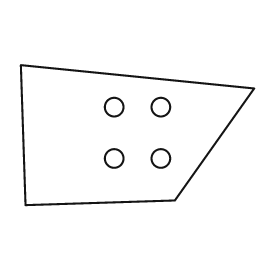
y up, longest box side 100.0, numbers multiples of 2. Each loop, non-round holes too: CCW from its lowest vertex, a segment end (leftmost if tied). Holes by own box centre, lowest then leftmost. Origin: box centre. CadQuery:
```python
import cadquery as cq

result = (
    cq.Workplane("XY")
    .moveTo(-48.0, -30.0)
    .lineTo(16.0, -28.0)
    .lineTo(50.0, 20.0)
    .lineTo(-50.0, 30.0)
    .close()
    .moveTo(-10.0, -10.0)
    .circle(4.0)
    .moveTo(10.0, -10.0)
    .circle(4.0)
    .moveTo(-10.0, 12.0)
    .circle(4.0)
    .moveTo(10.0, 12.0)
    .circle(4.0)
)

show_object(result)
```